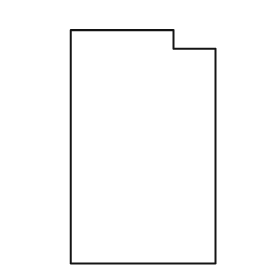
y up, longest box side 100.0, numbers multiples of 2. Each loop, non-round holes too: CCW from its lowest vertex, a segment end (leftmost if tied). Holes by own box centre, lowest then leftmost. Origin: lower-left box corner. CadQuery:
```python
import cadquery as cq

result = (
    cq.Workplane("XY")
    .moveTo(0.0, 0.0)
    .lineTo(62.0, 0.0)
    .lineTo(62.0, 92.0)
    .lineTo(44.0, 92.0)
    .lineTo(44.0, 100.0)
    .lineTo(0.0, 100.0)
    .close()
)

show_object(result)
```